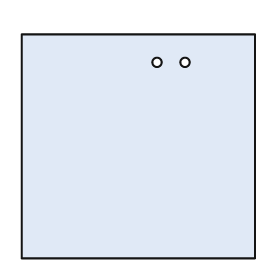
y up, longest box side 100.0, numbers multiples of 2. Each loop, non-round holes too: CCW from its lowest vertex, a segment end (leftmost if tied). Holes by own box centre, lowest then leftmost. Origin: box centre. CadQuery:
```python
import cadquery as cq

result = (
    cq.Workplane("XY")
    .moveTo(-50.0, -48.0)
    .lineTo(50.0, -48.0)
    .lineTo(50.0, 48.0)
    .lineTo(-50.0, 48.0)
    .close()
    .moveTo(8.0, 36.0)
    .circle(2.0)
    .moveTo(20.0, 36.0)
    .circle(2.0)
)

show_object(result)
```